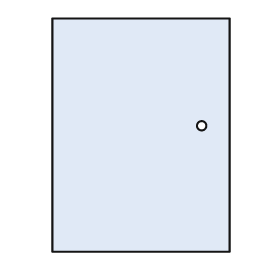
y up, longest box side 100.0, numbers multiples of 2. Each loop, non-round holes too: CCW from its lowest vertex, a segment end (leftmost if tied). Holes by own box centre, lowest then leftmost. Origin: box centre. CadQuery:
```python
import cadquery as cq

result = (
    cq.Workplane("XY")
    .moveTo(-38.0, -50.0)
    .lineTo(38.0, -50.0)
    .lineTo(38.0, 50.0)
    .lineTo(-38.0, 50.0)
    .close()
    .moveTo(26.0, 4.0)
    .circle(2.0)
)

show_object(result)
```